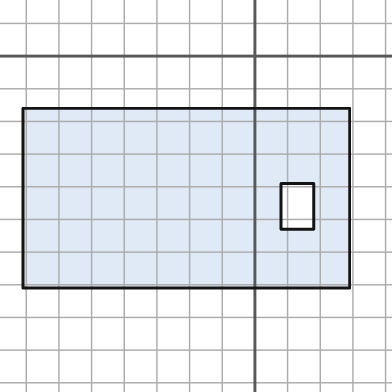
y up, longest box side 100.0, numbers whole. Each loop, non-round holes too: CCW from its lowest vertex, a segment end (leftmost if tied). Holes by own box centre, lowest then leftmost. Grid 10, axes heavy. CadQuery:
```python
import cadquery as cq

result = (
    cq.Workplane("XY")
    .moveTo(-71.0, -71.0)
    .lineTo(29.0, -71.0)
    .lineTo(29.0, -16.0)
    .lineTo(-71.0, -16.0)
    .close()
    .moveTo(8.0, -53.0)
    .lineTo(18.0, -53.0)
    .lineTo(18.0, -39.0)
    .lineTo(8.0, -39.0)
    .close()
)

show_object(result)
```